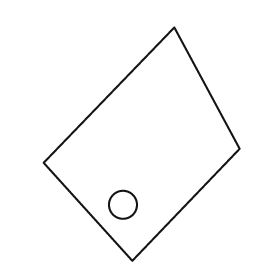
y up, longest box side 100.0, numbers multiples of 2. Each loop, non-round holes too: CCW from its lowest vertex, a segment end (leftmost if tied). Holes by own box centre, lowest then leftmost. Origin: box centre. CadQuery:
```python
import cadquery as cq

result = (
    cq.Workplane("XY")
    .moveTo(-4.0, -50.0)
    .lineTo(42.0, -2.0)
    .lineTo(14.0, 50.0)
    .lineTo(-42.0, -8.0)
    .close()
    .moveTo(-8.0, -26.0)
    .circle(6.0)
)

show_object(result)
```